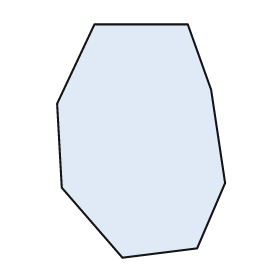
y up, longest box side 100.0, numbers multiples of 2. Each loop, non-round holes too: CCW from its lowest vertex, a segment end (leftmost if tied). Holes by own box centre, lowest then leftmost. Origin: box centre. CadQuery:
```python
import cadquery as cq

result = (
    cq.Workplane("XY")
    .moveTo(-8.0, -50.0)
    .lineTo(24.0, -46.0)
    .lineTo(36.0, -18.0)
    .lineTo(30.0, 22.0)
    .lineTo(20.0, 50.0)
    .lineTo(-20.0, 50.0)
    .lineTo(-36.0, 16.0)
    .lineTo(-34.0, -20.0)
    .close()
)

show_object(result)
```